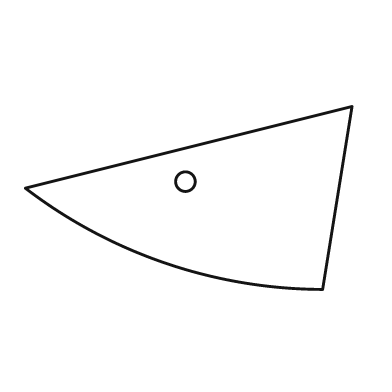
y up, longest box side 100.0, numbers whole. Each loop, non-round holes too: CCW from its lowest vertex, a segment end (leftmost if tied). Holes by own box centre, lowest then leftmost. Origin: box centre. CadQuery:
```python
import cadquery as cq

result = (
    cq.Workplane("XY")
    .moveTo(41.0, -28.0)
    .lineTo(50.0, 28.0)
    .lineTo(-50.0, 3.0)
    .threePointArc((-7.0, -20.0), (41.0, -28.0))
    .close()
    .moveTo(-1.0, 5.0)
    .circle(3.0)
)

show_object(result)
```